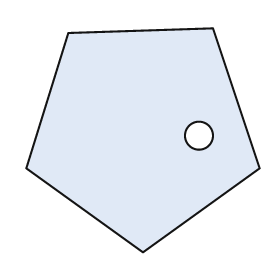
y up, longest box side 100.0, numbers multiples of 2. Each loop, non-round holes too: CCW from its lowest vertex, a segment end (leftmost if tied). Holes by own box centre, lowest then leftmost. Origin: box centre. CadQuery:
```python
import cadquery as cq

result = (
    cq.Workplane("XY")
    .moveTo(0.0, -48.0)
    .lineTo(50.0, -12.0)
    .lineTo(30.0, 48.0)
    .lineTo(-32.0, 46.0)
    .lineTo(-50.0, -12.0)
    .close()
    .moveTo(24.0, 2.0)
    .circle(6.0)
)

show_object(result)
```